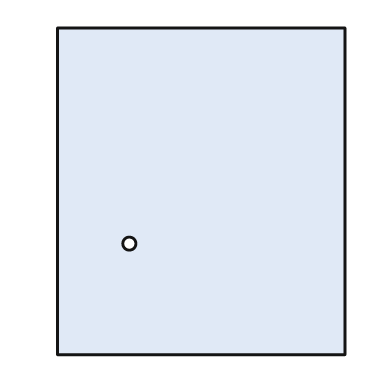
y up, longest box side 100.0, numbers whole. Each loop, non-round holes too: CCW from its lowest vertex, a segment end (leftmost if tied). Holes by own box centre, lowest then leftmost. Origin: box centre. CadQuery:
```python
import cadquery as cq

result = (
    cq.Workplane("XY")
    .moveTo(-44.0, -50.0)
    .lineTo(44.0, -50.0)
    .lineTo(44.0, 50.0)
    .lineTo(-44.0, 50.0)
    .close()
    .moveTo(-22.0, -16.0)
    .circle(2.0)
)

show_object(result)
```